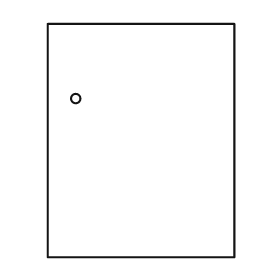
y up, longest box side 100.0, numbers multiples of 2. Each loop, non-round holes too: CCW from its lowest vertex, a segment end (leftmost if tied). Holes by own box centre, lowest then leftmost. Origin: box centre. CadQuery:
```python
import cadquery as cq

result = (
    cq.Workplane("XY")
    .moveTo(-40.0, -50.0)
    .lineTo(40.0, -50.0)
    .lineTo(40.0, 50.0)
    .lineTo(-40.0, 50.0)
    .close()
    .moveTo(-28.0, 18.0)
    .circle(2.0)
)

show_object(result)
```